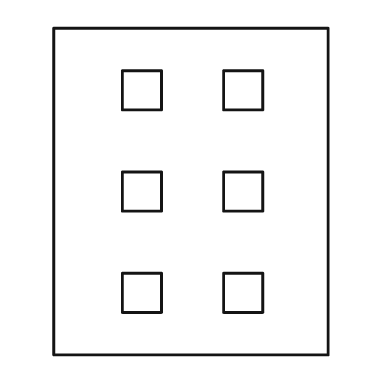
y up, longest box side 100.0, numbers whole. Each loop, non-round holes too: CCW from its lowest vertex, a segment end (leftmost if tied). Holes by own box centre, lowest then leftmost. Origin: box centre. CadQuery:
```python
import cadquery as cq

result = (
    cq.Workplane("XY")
    .moveTo(-42.0, -50.0)
    .lineTo(42.0, -50.0)
    .lineTo(42.0, 50.0)
    .lineTo(-42.0, 50.0)
    .close()
    .moveTo(-21.0, -37.0)
    .lineTo(-9.0, -37.0)
    .lineTo(-9.0, -25.0)
    .lineTo(-21.0, -25.0)
    .close()
    .moveTo(10.0, -37.0)
    .lineTo(22.0, -37.0)
    .lineTo(22.0, -25.0)
    .lineTo(10.0, -25.0)
    .close()
    .moveTo(-21.0, -6.0)
    .lineTo(-9.0, -6.0)
    .lineTo(-9.0, 6.0)
    .lineTo(-21.0, 6.0)
    .close()
    .moveTo(10.0, -6.0)
    .lineTo(22.0, -6.0)
    .lineTo(22.0, 6.0)
    .lineTo(10.0, 6.0)
    .close()
    .moveTo(-21.0, 25.0)
    .lineTo(-9.0, 25.0)
    .lineTo(-9.0, 37.0)
    .lineTo(-21.0, 37.0)
    .close()
    .moveTo(10.0, 25.0)
    .lineTo(22.0, 25.0)
    .lineTo(22.0, 37.0)
    .lineTo(10.0, 37.0)
    .close()
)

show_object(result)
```